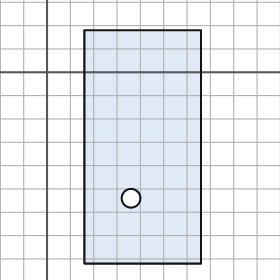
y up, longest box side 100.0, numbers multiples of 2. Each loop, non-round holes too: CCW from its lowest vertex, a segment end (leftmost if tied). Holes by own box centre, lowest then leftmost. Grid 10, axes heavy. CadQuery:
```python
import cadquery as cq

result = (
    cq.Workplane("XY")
    .moveTo(16.0, -82.0)
    .lineTo(66.0, -82.0)
    .lineTo(66.0, 18.0)
    .lineTo(16.0, 18.0)
    .close()
    .moveTo(36.0, -54.0)
    .circle(4.0)
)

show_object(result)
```